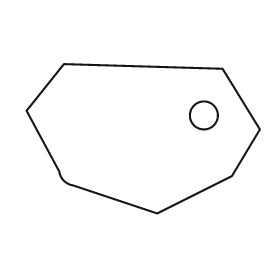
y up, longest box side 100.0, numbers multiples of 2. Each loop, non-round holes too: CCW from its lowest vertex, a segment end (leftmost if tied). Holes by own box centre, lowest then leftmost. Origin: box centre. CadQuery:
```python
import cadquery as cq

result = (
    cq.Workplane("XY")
    .moveTo(6.0, -32.0)
    .lineTo(38.0, -16.0)
    .lineTo(50.0, 4.0)
    .lineTo(34.0, 30.0)
    .lineTo(-34.0, 32.0)
    .lineTo(-50.0, 12.0)
    .lineTo(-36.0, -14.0)
    .threePointArc((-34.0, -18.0), (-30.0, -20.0))
    .close()
    .moveTo(26.0, 10.0)
    .circle(6.0)
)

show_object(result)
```